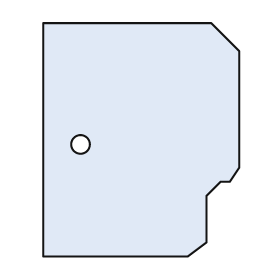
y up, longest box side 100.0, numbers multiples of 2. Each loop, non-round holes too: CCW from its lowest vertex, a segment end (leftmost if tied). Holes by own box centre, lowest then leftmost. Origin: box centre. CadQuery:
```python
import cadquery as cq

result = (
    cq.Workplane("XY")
    .moveTo(-42.0, -50.0)
    .lineTo(20.0, -50.0)
    .lineTo(28.0, -44.0)
    .lineTo(28.0, -24.0)
    .lineTo(34.0, -18.0)
    .lineTo(38.0, -18.0)
    .lineTo(42.0, -12.0)
    .lineTo(42.0, 38.0)
    .lineTo(30.0, 50.0)
    .lineTo(-42.0, 50.0)
    .close()
    .moveTo(-26.0, -2.0)
    .circle(4.0)
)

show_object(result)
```